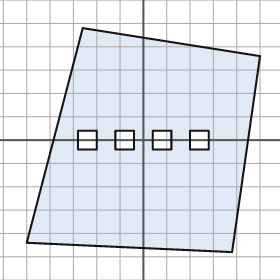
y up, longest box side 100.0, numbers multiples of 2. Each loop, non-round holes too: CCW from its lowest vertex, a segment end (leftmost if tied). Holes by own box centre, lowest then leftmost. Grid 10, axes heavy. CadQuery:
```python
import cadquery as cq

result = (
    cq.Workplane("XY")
    .moveTo(38.0, -48.0)
    .lineTo(50.0, 36.0)
    .lineTo(-26.0, 48.0)
    .lineTo(-50.0, -44.0)
    .close()
    .moveTo(-28.0, -4.0)
    .lineTo(-20.0, -4.0)
    .lineTo(-20.0, 4.0)
    .lineTo(-28.0, 4.0)
    .close()
    .moveTo(-12.0, -4.0)
    .lineTo(-4.0, -4.0)
    .lineTo(-4.0, 4.0)
    .lineTo(-12.0, 4.0)
    .close()
    .moveTo(4.0, -4.0)
    .lineTo(12.0, -4.0)
    .lineTo(12.0, 4.0)
    .lineTo(4.0, 4.0)
    .close()
    .moveTo(20.0, -4.0)
    .lineTo(28.0, -4.0)
    .lineTo(28.0, 4.0)
    .lineTo(20.0, 4.0)
    .close()
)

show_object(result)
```